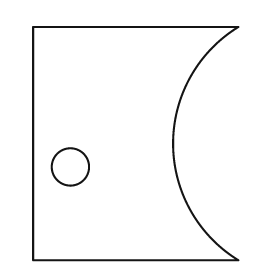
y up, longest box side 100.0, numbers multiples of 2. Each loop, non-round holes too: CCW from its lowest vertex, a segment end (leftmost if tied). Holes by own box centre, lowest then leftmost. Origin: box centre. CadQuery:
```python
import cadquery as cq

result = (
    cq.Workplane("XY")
    .moveTo(-44.0, -50.0)
    .lineTo(44.0, -50.0)
    .threePointArc((16.0, 0.0), (44.0, 50.0))
    .lineTo(-44.0, 50.0)
    .close()
    .moveTo(-28.0, -10.0)
    .circle(8.0)
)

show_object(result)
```